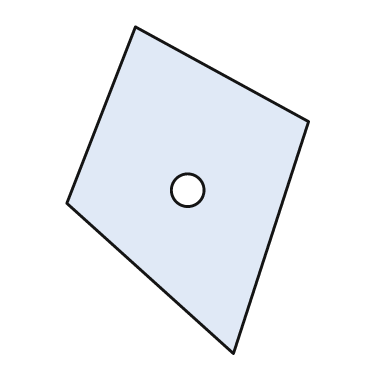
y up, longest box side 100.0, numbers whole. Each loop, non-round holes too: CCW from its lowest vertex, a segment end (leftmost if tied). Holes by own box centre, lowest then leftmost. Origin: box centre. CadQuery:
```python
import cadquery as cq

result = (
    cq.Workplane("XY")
    .moveTo(14.0, -50.0)
    .lineTo(37.0, 21.0)
    .lineTo(-16.0, 50.0)
    .lineTo(-37.0, -4.0)
    .close()
    .moveTo(0.0, 0.0)
    .circle(5.0)
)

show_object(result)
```